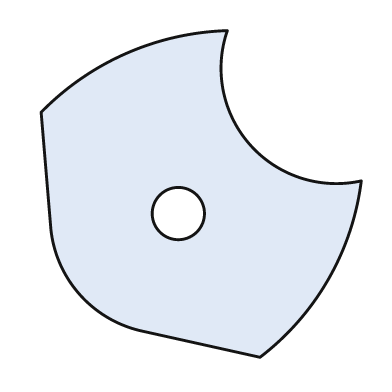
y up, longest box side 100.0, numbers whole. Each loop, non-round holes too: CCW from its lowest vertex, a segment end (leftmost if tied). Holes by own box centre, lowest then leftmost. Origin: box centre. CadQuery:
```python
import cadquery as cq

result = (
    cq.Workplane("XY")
    .moveTo(18.0, -50.0)
    .threePointArc((39.0, -26.0), (49.0, 4.0))
    .threePointArc((15.0, 15.0), (8.0, 50.0))
    .threePointArc((-23.0, 43.0), (-49.0, 25.0))
    .lineTo(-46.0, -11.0)
    .threePointArc((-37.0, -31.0), (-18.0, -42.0))
    .close()
    .moveTo(-7.0, -6.0)
    .circle(8.0)
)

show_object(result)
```